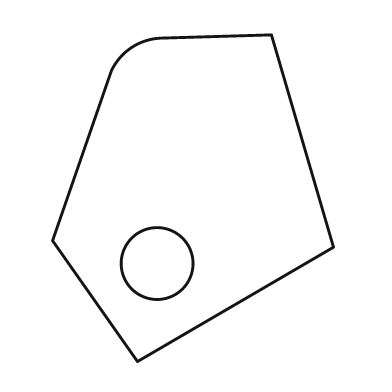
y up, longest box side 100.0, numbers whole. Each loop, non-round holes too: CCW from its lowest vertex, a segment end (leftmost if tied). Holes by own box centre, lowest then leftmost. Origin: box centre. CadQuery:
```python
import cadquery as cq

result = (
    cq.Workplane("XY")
    .moveTo(-17.0, -50.0)
    .lineTo(43.0, -15.0)
    .lineTo(24.0, 50.0)
    .lineTo(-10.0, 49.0)
    .threePointArc((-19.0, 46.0), (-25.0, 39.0))
    .lineTo(-43.0, -13.0)
    .close()
    .moveTo(-11.0, -20.0)
    .circle(11.0)
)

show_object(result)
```